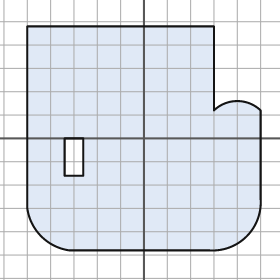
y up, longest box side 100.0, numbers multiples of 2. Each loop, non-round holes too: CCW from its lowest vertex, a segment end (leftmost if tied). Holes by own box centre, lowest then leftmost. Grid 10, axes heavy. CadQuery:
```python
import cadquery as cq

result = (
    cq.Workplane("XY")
    .moveTo(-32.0, -48.0)
    .lineTo(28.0, -48.0)
    .threePointArc((44.0, -42.0), (50.0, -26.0))
    .lineTo(50.0, 12.0)
    .threePointArc((40.0, 16.0), (30.0, 12.0))
    .lineTo(30.0, 48.0)
    .lineTo(-50.0, 48.0)
    .lineTo(-50.0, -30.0)
    .threePointArc((-44.0, -42.0), (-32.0, -48.0))
    .close()
    .moveTo(-34.0, -16.0)
    .lineTo(-26.0, -16.0)
    .lineTo(-26.0, 0.0)
    .lineTo(-34.0, 0.0)
    .close()
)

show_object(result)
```